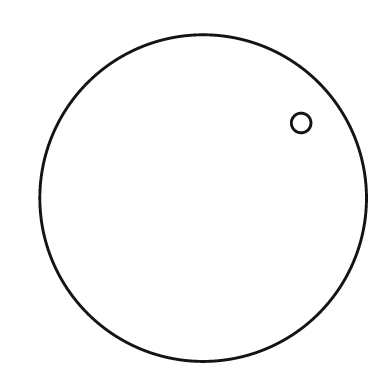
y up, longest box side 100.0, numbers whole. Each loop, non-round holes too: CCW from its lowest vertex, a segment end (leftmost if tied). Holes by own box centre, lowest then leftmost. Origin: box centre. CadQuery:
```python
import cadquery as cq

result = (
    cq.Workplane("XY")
    .moveTo(0.0, 0.0)
    .circle(50.0)
    .moveTo(30.0, 23.0)
    .circle(3.0)
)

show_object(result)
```